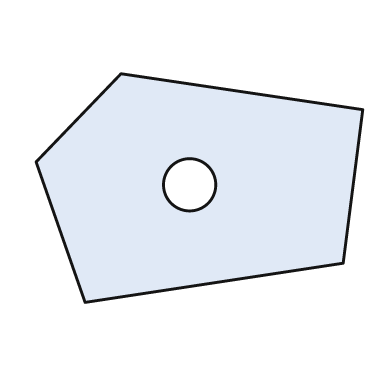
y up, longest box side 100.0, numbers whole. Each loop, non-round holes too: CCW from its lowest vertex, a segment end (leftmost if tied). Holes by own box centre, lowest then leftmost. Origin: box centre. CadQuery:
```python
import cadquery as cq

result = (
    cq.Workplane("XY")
    .moveTo(-35.0, -35.0)
    .lineTo(44.0, -23.0)
    .lineTo(50.0, 24.0)
    .lineTo(-24.0, 35.0)
    .lineTo(-50.0, 8.0)
    .close()
    .moveTo(-3.0, 1.0)
    .circle(8.0)
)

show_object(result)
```